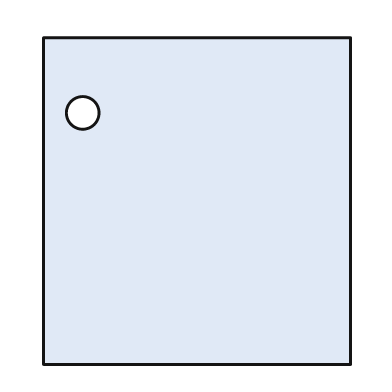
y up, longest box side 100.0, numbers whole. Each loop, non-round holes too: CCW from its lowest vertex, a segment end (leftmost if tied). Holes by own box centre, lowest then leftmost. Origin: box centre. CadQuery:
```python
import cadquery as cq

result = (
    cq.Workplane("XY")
    .moveTo(-47.0, -50.0)
    .lineTo(47.0, -50.0)
    .lineTo(47.0, 50.0)
    .lineTo(-47.0, 50.0)
    .close()
    .moveTo(-35.0, 27.0)
    .circle(5.0)
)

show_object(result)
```